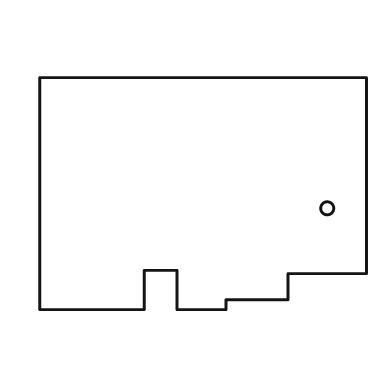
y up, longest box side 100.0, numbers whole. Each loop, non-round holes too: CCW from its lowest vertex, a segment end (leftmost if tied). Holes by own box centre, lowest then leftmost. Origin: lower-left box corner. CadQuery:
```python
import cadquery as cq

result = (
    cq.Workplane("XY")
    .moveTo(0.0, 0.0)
    .lineTo(32.0, 0.0)
    .lineTo(32.0, 12.0)
    .lineTo(42.0, 12.0)
    .lineTo(42.0, 0.0)
    .lineTo(57.0, 0.0)
    .lineTo(57.0, 3.0)
    .lineTo(76.0, 3.0)
    .lineTo(76.0, 11.0)
    .lineTo(100.0, 11.0)
    .lineTo(100.0, 71.0)
    .lineTo(0.0, 71.0)
    .close()
    .moveTo(88.0, 31.0)
    .circle(2.0)
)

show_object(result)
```